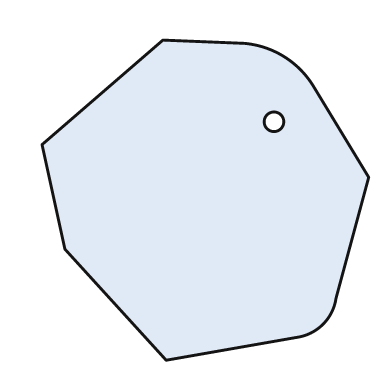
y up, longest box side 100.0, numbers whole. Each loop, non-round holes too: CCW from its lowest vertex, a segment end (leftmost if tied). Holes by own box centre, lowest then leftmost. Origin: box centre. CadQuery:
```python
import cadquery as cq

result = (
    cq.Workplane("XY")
    .moveTo(-12.0, -49.0)
    .lineTo(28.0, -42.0)
    .threePointArc((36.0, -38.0), (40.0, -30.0))
    .lineTo(50.0, 7.0)
    .lineTo(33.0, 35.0)
    .threePointArc((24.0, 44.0), (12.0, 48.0))
    .lineTo(-13.0, 49.0)
    .lineTo(-50.0, 17.0)
    .lineTo(-43.0, -15.0)
    .close()
    .moveTo(21.0, 24.0)
    .circle(3.0)
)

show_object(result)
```